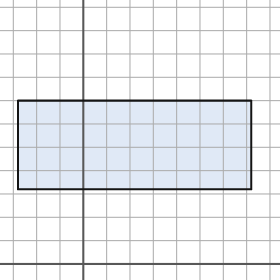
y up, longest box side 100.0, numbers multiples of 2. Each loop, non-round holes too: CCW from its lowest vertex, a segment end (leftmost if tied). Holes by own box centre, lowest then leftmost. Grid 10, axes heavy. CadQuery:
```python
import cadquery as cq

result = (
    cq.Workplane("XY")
    .moveTo(-28.0, 32.0)
    .lineTo(72.0, 32.0)
    .lineTo(72.0, 70.0)
    .lineTo(-28.0, 70.0)
    .close()
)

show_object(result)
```